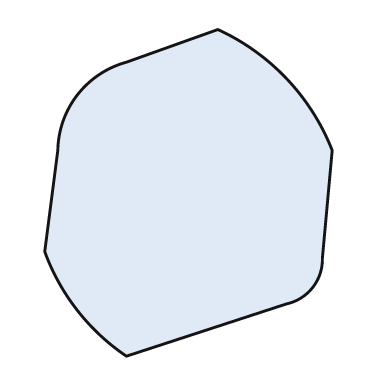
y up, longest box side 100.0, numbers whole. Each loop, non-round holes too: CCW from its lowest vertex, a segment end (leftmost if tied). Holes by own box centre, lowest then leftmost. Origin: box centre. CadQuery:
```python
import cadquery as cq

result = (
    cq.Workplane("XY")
    .moveTo(-19.0, -50.0)
    .lineTo(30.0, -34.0)
    .threePointArc((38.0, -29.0), (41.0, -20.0))
    .lineTo(44.0, 13.0)
    .threePointArc((30.0, 35.0), (9.0, 50.0))
    .lineTo(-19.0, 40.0)
    .threePointArc((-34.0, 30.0), (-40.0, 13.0))
    .lineTo(-44.0, -18.0)
    .threePointArc((-34.0, -36.0), (-19.0, -50.0))
    .close()
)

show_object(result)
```